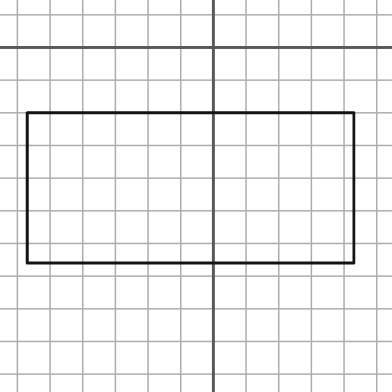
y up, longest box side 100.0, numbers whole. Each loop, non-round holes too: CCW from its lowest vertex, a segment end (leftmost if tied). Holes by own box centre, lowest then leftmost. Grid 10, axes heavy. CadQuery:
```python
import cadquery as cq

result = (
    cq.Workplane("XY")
    .moveTo(-57.0, -66.0)
    .lineTo(43.0, -66.0)
    .lineTo(43.0, -20.0)
    .lineTo(-57.0, -20.0)
    .close()
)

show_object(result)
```